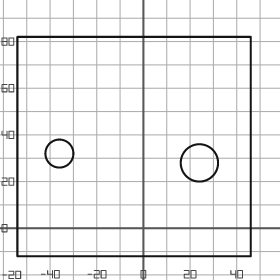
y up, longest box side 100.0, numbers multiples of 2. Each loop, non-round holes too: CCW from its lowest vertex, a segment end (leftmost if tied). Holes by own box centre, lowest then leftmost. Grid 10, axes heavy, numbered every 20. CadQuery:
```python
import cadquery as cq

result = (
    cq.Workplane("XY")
    .moveTo(-54.0, -12.0)
    .lineTo(46.0, -12.0)
    .lineTo(46.0, 82.0)
    .lineTo(-54.0, 82.0)
    .close()
    .moveTo(24.0, 28.0)
    .circle(8.0)
    .moveTo(-36.0, 32.0)
    .circle(6.0)
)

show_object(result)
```